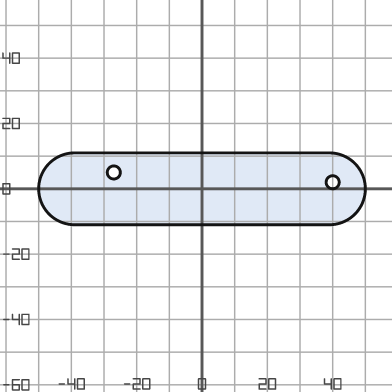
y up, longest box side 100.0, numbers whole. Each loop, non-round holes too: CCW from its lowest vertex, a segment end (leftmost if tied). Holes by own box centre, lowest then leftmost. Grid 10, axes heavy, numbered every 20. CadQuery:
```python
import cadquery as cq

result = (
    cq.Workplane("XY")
    .moveTo(-39.0, -11.0)
    .lineTo(39.0, -11.0)
    .threePointArc((50.0, 0.0), (39.0, 11.0))
    .lineTo(-39.0, 11.0)
    .threePointArc((-50.0, 0.0), (-39.0, -11.0))
    .close()
    .moveTo(40.0, 2.0)
    .circle(2.0)
    .moveTo(-27.0, 5.0)
    .circle(2.0)
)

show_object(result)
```